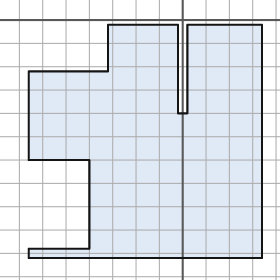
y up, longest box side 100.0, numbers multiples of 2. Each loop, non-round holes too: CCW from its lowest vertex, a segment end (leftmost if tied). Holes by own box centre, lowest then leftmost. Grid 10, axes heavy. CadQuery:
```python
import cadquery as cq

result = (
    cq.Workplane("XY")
    .moveTo(-66.0, -102.0)
    .lineTo(34.0, -102.0)
    .lineTo(34.0, -2.0)
    .lineTo(2.0, -2.0)
    .lineTo(2.0, -40.0)
    .lineTo(-2.0, -40.0)
    .lineTo(-2.0, -2.0)
    .lineTo(-32.0, -2.0)
    .lineTo(-32.0, -22.0)
    .lineTo(-66.0, -22.0)
    .lineTo(-66.0, -60.0)
    .lineTo(-40.0, -60.0)
    .lineTo(-40.0, -98.0)
    .lineTo(-66.0, -98.0)
    .close()
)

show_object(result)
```